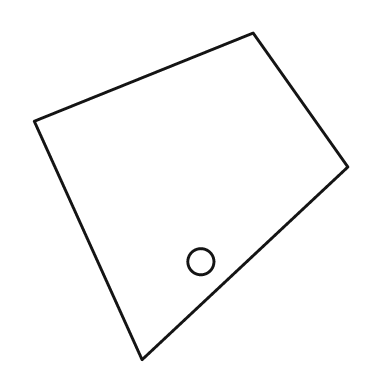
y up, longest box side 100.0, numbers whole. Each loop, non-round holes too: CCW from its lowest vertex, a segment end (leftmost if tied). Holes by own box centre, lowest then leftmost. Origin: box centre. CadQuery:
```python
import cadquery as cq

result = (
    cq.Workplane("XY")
    .moveTo(-15.0, -50.0)
    .lineTo(48.0, 9.0)
    .lineTo(19.0, 50.0)
    .lineTo(-48.0, 23.0)
    .close()
    .moveTo(3.0, -20.0)
    .circle(4.0)
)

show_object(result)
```